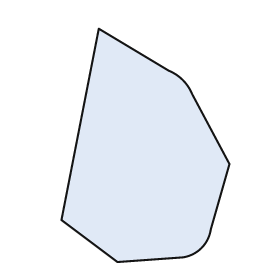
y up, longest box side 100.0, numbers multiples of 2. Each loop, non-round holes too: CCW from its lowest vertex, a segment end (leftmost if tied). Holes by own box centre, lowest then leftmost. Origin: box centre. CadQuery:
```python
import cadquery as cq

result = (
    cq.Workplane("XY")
    .moveTo(-12.0, -50.0)
    .lineTo(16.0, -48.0)
    .threePointArc((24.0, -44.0), (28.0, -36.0))
    .lineTo(36.0, -8.0)
    .lineTo(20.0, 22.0)
    .threePointArc((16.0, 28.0), (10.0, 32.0))
    .lineTo(-20.0, 50.0)
    .lineTo(-36.0, -32.0)
    .close()
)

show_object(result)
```